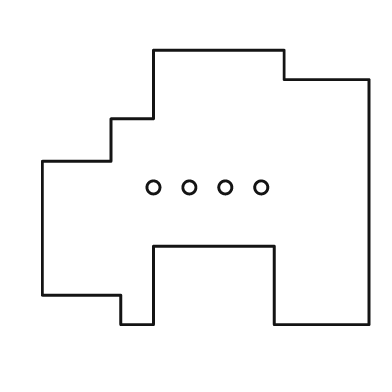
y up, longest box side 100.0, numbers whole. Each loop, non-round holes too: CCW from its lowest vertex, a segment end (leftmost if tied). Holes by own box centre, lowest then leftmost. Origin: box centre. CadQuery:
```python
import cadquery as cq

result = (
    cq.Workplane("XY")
    .moveTo(-26.0, -42.0)
    .lineTo(-16.0, -42.0)
    .lineTo(-16.0, -18.0)
    .lineTo(21.0, -18.0)
    .lineTo(21.0, -42.0)
    .lineTo(50.0, -42.0)
    .lineTo(50.0, 33.0)
    .lineTo(24.0, 33.0)
    .lineTo(24.0, 42.0)
    .lineTo(-16.0, 42.0)
    .lineTo(-16.0, 21.0)
    .lineTo(-29.0, 21.0)
    .lineTo(-29.0, 8.0)
    .lineTo(-50.0, 8.0)
    .lineTo(-50.0, -33.0)
    .lineTo(-26.0, -33.0)
    .close()
    .moveTo(-16.0, 0.0)
    .circle(2.0)
    .moveTo(-5.0, 0.0)
    .circle(2.0)
    .moveTo(6.0, 0.0)
    .circle(2.0)
    .moveTo(17.0, 0.0)
    .circle(2.0)
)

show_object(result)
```